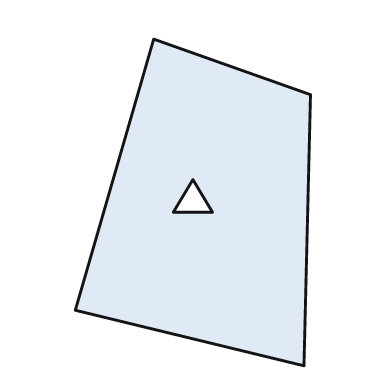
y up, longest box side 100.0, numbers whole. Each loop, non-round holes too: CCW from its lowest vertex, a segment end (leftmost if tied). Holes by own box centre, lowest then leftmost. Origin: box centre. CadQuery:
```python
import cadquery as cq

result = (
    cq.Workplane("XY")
    .moveTo(34.0, -50.0)
    .lineTo(36.0, 33.0)
    .lineTo(-12.0, 50.0)
    .lineTo(-36.0, -33.0)
    .close()
    .moveTo(-6.0, -3.0)
    .lineTo(6.0, -3.0)
    .lineTo(0.0, 7.0)
    .close()
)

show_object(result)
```